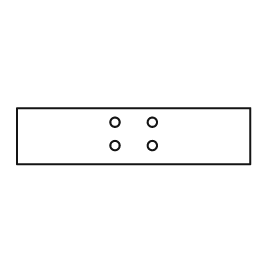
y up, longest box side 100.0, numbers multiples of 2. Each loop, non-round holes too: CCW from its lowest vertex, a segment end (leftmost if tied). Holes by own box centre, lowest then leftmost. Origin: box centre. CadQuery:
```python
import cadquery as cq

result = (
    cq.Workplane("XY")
    .moveTo(-50.0, -12.0)
    .lineTo(50.0, -12.0)
    .lineTo(50.0, 12.0)
    .lineTo(-50.0, 12.0)
    .close()
    .moveTo(-8.0, -4.0)
    .circle(2.0)
    .moveTo(8.0, -4.0)
    .circle(2.0)
    .moveTo(-8.0, 6.0)
    .circle(2.0)
    .moveTo(8.0, 6.0)
    .circle(2.0)
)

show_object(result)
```